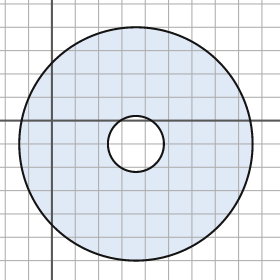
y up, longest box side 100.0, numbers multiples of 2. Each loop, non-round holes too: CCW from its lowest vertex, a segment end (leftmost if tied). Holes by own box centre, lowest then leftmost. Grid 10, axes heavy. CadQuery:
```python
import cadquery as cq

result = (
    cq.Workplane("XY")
    .moveTo(36.0, -10.0)
    .circle(50.0)
    .moveTo(36.0, -10.0)
    .circle(12.0)
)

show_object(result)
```